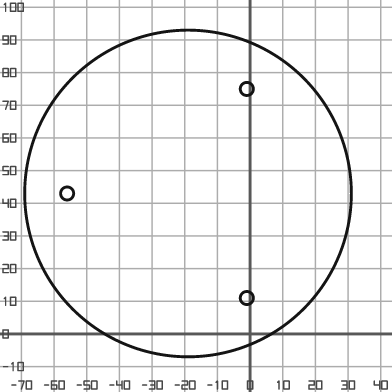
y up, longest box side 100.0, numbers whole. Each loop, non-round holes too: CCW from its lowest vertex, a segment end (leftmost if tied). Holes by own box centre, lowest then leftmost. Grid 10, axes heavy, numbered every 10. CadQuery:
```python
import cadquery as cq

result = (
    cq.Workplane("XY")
    .moveTo(-19.0, 43.0)
    .circle(50.0)
    .moveTo(-1.0, 11.0)
    .circle(2.0)
    .moveTo(-56.0, 43.0)
    .circle(2.0)
    .moveTo(-1.0, 75.0)
    .circle(2.0)
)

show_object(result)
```